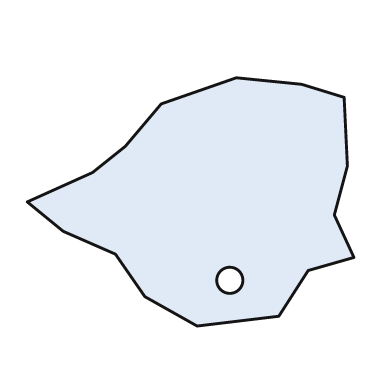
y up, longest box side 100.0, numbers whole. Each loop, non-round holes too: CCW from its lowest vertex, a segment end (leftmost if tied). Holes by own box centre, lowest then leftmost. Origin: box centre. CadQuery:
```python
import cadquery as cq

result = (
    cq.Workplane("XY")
    .moveTo(2.0, -38.0)
    .lineTo(27.0, -35.0)
    .lineTo(36.0, -21.0)
    .lineTo(50.0, -17.0)
    .lineTo(44.0, -4.0)
    .lineTo(48.0, 11.0)
    .lineTo(47.0, 32.0)
    .lineTo(34.0, 36.0)
    .lineTo(14.0, 38.0)
    .lineTo(-9.0, 30.0)
    .lineTo(-20.0, 17.0)
    .lineTo(-30.0, 9.0)
    .lineTo(-50.0, 0.0)
    .lineTo(-39.0, -9.0)
    .lineTo(-23.0, -16.0)
    .lineTo(-14.0, -29.0)
    .close()
    .moveTo(12.0, -24.0)
    .circle(4.0)
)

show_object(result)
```